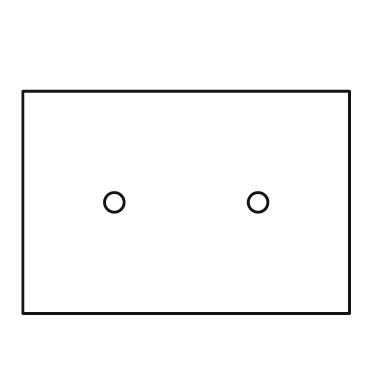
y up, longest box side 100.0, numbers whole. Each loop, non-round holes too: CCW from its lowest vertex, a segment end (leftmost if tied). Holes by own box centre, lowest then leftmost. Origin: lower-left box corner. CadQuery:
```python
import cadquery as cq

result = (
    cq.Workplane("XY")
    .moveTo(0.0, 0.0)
    .lineTo(100.0, 0.0)
    .lineTo(100.0, 68.0)
    .lineTo(0.0, 68.0)
    .close()
    .moveTo(28.0, 34.0)
    .circle(3.0)
    .moveTo(72.0, 34.0)
    .circle(3.0)
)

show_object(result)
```